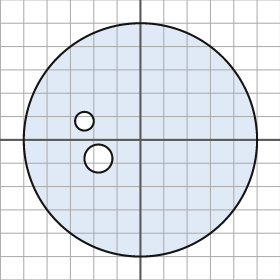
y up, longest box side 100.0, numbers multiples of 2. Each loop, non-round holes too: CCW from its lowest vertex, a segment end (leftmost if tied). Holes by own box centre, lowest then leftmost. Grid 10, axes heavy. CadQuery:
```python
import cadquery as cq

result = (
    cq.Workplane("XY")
    .moveTo(0.0, 0.0)
    .circle(50.0)
    .moveTo(-18.0, -8.0)
    .circle(6.0)
    .moveTo(-24.0, 8.0)
    .circle(4.0)
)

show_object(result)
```